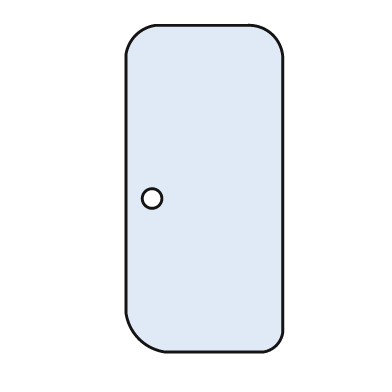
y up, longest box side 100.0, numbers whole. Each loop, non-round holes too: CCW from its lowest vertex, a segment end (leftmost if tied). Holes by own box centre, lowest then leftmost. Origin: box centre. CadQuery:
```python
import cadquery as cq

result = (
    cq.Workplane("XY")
    .moveTo(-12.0, -50.0)
    .lineTo(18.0, -50.0)
    .threePointArc((22.0, -48.0), (24.0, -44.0))
    .lineTo(24.0, 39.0)
    .threePointArc((21.0, 47.0), (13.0, 50.0))
    .lineTo(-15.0, 50.0)
    .threePointArc((-21.0, 47.0), (-24.0, 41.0))
    .lineTo(-24.0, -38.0)
    .threePointArc((-20.0, -46.0), (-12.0, -50.0))
    .close()
    .moveTo(-16.0, -3.0)
    .circle(3.0)
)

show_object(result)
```